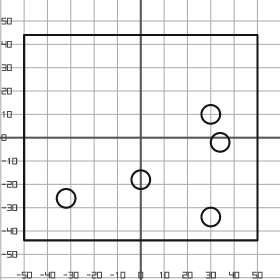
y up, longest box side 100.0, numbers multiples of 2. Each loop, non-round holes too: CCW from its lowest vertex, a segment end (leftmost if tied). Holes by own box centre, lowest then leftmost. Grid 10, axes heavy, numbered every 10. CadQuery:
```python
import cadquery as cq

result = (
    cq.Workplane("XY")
    .moveTo(-50.0, -44.0)
    .lineTo(50.0, -44.0)
    .lineTo(50.0, 44.0)
    .lineTo(-50.0, 44.0)
    .close()
    .moveTo(30.0, -34.0)
    .circle(4.0)
    .moveTo(-32.0, -26.0)
    .circle(4.0)
    .moveTo(0.0, -18.0)
    .circle(4.0)
    .moveTo(34.0, -2.0)
    .circle(4.0)
    .moveTo(30.0, 10.0)
    .circle(4.0)
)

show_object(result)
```